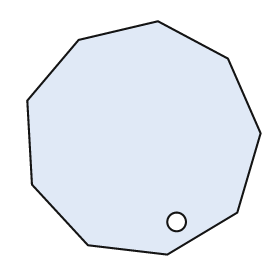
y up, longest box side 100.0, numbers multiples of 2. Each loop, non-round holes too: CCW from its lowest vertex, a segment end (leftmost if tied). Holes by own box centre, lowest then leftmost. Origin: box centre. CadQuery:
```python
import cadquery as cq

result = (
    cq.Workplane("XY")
    .moveTo(10.0, -50.0)
    .lineTo(40.0, -32.0)
    .lineTo(50.0, 2.0)
    .lineTo(36.0, 34.0)
    .lineTo(6.0, 50.0)
    .lineTo(-28.0, 42.0)
    .lineTo(-50.0, 16.0)
    .lineTo(-48.0, -20.0)
    .lineTo(-24.0, -46.0)
    .close()
    .moveTo(14.0, -36.0)
    .circle(4.0)
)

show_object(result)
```